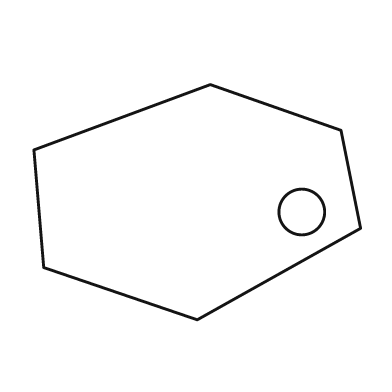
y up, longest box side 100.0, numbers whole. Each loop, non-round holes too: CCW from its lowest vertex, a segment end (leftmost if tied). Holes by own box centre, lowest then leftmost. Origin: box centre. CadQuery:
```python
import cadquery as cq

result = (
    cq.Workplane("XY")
    .moveTo(0.0, -36.0)
    .lineTo(50.0, -8.0)
    .lineTo(44.0, 22.0)
    .lineTo(4.0, 36.0)
    .lineTo(-50.0, 16.0)
    .lineTo(-47.0, -20.0)
    .close()
    .moveTo(32.0, -3.0)
    .circle(7.0)
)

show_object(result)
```